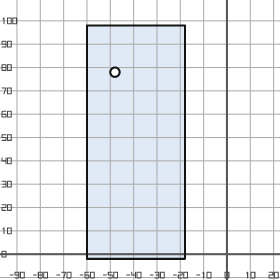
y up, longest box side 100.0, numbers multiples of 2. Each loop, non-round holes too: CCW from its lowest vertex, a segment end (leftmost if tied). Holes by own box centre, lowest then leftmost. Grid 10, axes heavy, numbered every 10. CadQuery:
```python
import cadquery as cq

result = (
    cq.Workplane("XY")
    .moveTo(-60.0, -2.0)
    .lineTo(-18.0, -2.0)
    .lineTo(-18.0, 98.0)
    .lineTo(-60.0, 98.0)
    .close()
    .moveTo(-48.0, 78.0)
    .circle(2.0)
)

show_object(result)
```